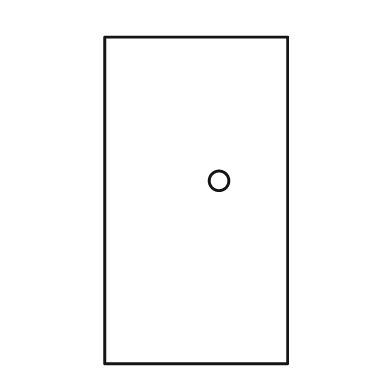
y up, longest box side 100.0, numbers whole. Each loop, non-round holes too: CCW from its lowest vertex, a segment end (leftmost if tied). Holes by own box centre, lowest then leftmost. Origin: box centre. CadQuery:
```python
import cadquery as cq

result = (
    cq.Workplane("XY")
    .moveTo(-28.0, -50.0)
    .lineTo(28.0, -50.0)
    .lineTo(28.0, 50.0)
    .lineTo(-28.0, 50.0)
    .close()
    .moveTo(7.0, 6.0)
    .circle(3.0)
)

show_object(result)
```